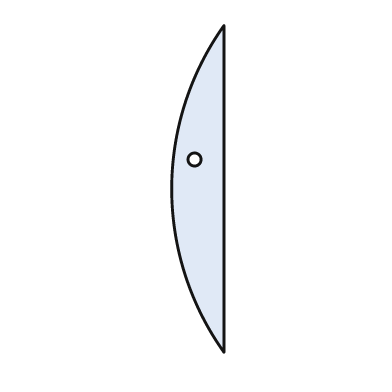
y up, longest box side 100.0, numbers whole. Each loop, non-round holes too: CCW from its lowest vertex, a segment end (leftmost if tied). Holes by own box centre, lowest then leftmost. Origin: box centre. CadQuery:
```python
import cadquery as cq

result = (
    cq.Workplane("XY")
    .moveTo(8.0, -50.0)
    .lineTo(8.0, 50.0)
    .threePointArc((-8.0, 0.0), (8.0, -50.0))
    .close()
    .moveTo(-1.0, 9.0)
    .circle(2.0)
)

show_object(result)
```